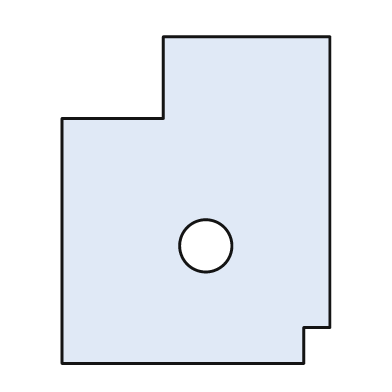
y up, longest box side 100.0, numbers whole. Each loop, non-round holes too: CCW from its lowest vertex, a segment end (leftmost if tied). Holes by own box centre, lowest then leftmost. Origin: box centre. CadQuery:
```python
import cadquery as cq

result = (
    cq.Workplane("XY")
    .moveTo(-41.0, -50.0)
    .lineTo(33.0, -50.0)
    .lineTo(33.0, -39.0)
    .lineTo(41.0, -39.0)
    .lineTo(41.0, 50.0)
    .lineTo(-10.0, 50.0)
    .lineTo(-10.0, 25.0)
    .lineTo(-41.0, 25.0)
    .close()
    .moveTo(3.0, -14.0)
    .circle(8.0)
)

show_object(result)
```